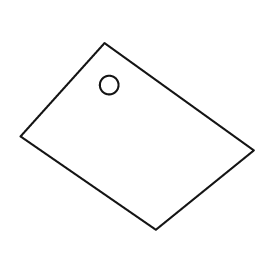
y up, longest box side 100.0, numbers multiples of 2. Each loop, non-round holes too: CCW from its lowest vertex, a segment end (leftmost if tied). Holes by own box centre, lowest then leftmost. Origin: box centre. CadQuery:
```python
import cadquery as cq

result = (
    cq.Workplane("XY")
    .moveTo(8.0, -40.0)
    .lineTo(50.0, -6.0)
    .lineTo(-14.0, 40.0)
    .lineTo(-50.0, 0.0)
    .close()
    .moveTo(-12.0, 22.0)
    .circle(4.0)
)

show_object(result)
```